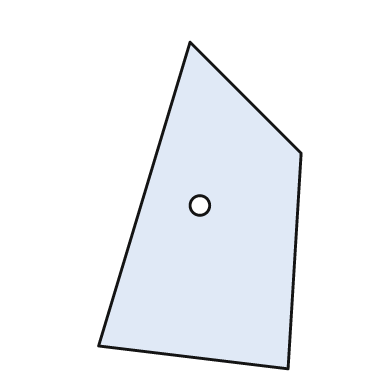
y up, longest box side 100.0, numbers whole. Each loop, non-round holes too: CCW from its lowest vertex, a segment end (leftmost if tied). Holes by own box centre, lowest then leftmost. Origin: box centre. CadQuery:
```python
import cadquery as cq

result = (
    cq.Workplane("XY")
    .moveTo(27.0, -50.0)
    .lineTo(31.0, 16.0)
    .lineTo(-3.0, 50.0)
    .lineTo(-31.0, -43.0)
    .close()
    .moveTo(0.0, 0.0)
    .circle(3.0)
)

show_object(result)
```